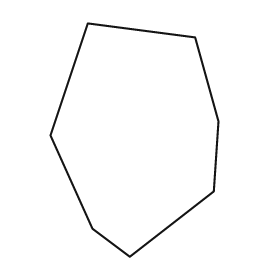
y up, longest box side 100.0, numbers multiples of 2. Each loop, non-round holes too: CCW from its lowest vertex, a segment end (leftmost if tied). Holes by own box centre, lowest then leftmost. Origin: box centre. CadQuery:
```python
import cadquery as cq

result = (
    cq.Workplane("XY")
    .moveTo(-2.0, -50.0)
    .lineTo(34.0, -22.0)
    .lineTo(36.0, 8.0)
    .lineTo(26.0, 44.0)
    .lineTo(-20.0, 50.0)
    .lineTo(-36.0, 2.0)
    .lineTo(-18.0, -38.0)
    .close()
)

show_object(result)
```